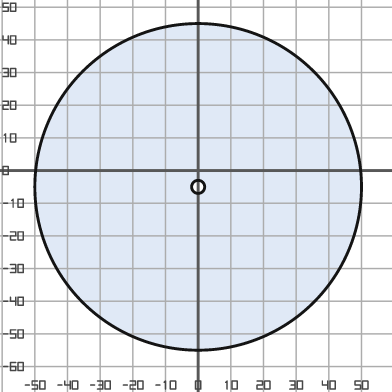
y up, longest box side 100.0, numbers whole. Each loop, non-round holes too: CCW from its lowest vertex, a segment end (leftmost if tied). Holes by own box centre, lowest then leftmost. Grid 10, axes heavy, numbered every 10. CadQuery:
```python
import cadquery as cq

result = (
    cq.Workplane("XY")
    .moveTo(0.0, -5.0)
    .circle(50.0)
    .moveTo(0.0, -5.0)
    .circle(2.0)
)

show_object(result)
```